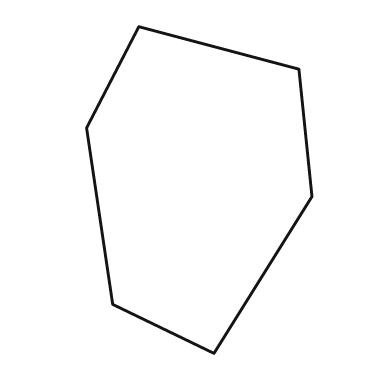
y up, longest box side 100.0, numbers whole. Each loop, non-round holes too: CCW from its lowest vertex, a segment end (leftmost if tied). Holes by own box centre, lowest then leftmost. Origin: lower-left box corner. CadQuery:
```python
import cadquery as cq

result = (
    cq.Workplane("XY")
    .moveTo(39.0, 0.0)
    .lineTo(69.0, 48.0)
    .lineTo(65.0, 87.0)
    .lineTo(16.0, 100.0)
    .lineTo(0.0, 69.0)
    .lineTo(8.0, 15.0)
    .close()
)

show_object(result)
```